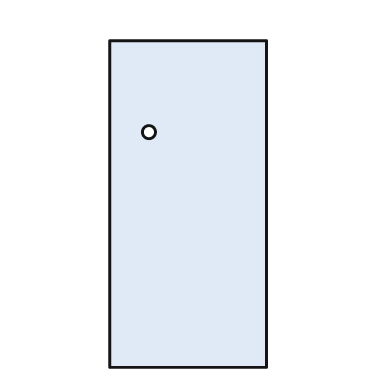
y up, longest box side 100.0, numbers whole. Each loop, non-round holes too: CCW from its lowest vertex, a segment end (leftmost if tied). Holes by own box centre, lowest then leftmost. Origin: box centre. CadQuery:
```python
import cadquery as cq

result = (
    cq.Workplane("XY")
    .moveTo(-24.0, -50.0)
    .lineTo(24.0, -50.0)
    .lineTo(24.0, 50.0)
    .lineTo(-24.0, 50.0)
    .close()
    .moveTo(-12.0, 22.0)
    .circle(2.0)
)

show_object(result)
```